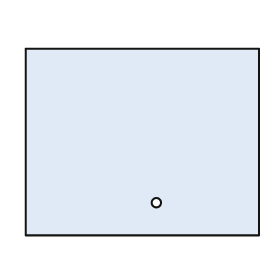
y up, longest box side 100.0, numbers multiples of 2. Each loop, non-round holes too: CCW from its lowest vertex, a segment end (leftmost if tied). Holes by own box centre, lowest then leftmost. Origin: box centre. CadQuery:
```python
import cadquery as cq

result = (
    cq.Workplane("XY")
    .moveTo(-50.0, -40.0)
    .lineTo(50.0, -40.0)
    .lineTo(50.0, 40.0)
    .lineTo(-50.0, 40.0)
    .close()
    .moveTo(6.0, -26.0)
    .circle(2.0)
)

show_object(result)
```